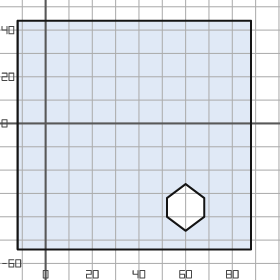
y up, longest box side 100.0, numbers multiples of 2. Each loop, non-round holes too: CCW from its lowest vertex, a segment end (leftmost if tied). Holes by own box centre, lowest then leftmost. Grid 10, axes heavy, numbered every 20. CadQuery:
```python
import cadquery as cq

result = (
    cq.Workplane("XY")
    .moveTo(-12.0, -54.0)
    .lineTo(88.0, -54.0)
    .lineTo(88.0, 44.0)
    .lineTo(-12.0, 44.0)
    .close()
    .moveTo(60.0, -46.0)
    .lineTo(68.0, -40.0)
    .lineTo(68.0, -32.0)
    .lineTo(60.0, -26.0)
    .lineTo(52.0, -32.0)
    .lineTo(52.0, -40.0)
    .close()
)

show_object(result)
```